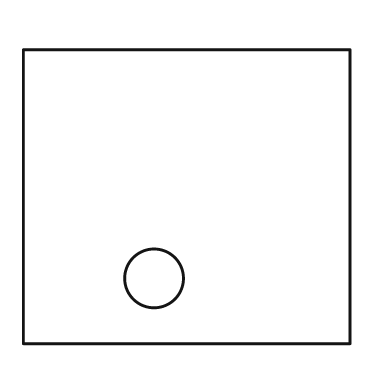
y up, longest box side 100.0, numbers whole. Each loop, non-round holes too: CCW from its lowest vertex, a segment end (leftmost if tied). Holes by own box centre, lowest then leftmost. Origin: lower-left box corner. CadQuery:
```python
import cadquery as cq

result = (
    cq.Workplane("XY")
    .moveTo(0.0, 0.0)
    .lineTo(100.0, 0.0)
    .lineTo(100.0, 90.0)
    .lineTo(0.0, 90.0)
    .close()
    .moveTo(40.0, 20.0)
    .circle(9.0)
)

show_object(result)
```